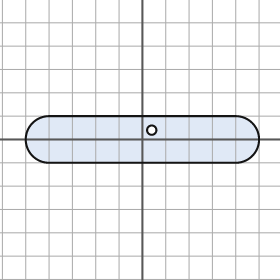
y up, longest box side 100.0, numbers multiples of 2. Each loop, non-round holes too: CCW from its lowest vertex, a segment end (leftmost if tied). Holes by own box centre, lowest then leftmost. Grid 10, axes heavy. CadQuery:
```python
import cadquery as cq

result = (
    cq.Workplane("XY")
    .moveTo(-40.0, -10.0)
    .lineTo(40.0, -10.0)
    .threePointArc((50.0, 0.0), (40.0, 10.0))
    .lineTo(-40.0, 10.0)
    .threePointArc((-50.0, 0.0), (-40.0, -10.0))
    .close()
    .moveTo(4.0, 4.0)
    .circle(2.0)
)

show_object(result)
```